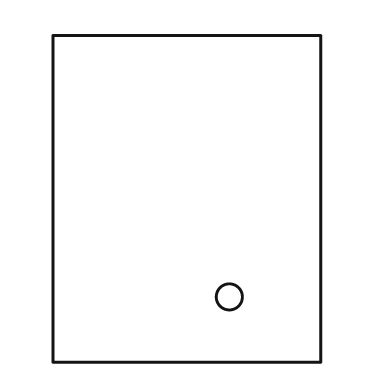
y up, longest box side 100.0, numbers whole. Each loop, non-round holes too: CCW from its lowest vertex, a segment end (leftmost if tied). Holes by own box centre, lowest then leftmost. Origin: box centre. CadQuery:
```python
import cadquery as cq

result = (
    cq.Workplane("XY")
    .moveTo(-41.0, -50.0)
    .lineTo(41.0, -50.0)
    .lineTo(41.0, 50.0)
    .lineTo(-41.0, 50.0)
    .close()
    .moveTo(13.0, -30.0)
    .circle(4.0)
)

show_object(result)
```